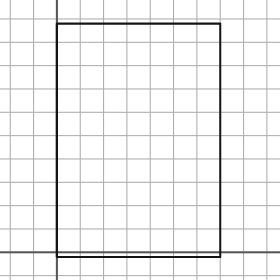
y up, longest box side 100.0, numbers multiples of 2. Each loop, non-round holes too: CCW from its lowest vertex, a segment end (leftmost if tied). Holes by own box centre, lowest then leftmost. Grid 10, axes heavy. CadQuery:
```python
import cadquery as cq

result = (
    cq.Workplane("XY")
    .moveTo(0.0, -2.0)
    .lineTo(70.0, -2.0)
    .lineTo(70.0, 98.0)
    .lineTo(0.0, 98.0)
    .close()
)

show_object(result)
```